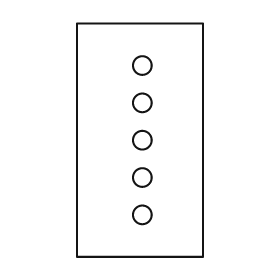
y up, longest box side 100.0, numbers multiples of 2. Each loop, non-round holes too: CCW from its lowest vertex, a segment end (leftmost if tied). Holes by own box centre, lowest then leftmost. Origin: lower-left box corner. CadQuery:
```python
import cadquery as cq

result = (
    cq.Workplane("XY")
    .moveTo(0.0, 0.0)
    .lineTo(54.0, 0.0)
    .lineTo(54.0, 100.0)
    .lineTo(0.0, 100.0)
    .close()
    .moveTo(28.0, 18.0)
    .circle(4.0)
    .moveTo(28.0, 34.0)
    .circle(4.0)
    .moveTo(28.0, 50.0)
    .circle(4.0)
    .moveTo(28.0, 66.0)
    .circle(4.0)
    .moveTo(28.0, 82.0)
    .circle(4.0)
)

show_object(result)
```